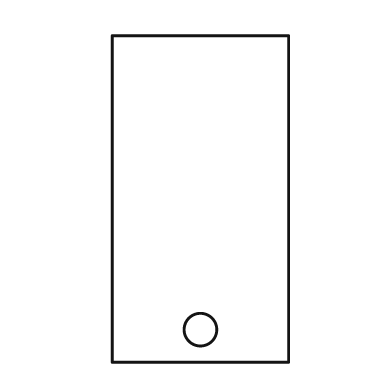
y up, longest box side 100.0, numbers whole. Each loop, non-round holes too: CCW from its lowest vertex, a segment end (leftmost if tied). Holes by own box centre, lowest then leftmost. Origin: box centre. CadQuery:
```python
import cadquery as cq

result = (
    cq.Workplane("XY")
    .moveTo(-27.0, -50.0)
    .lineTo(27.0, -50.0)
    .lineTo(27.0, 50.0)
    .lineTo(-27.0, 50.0)
    .close()
    .moveTo(0.0, -40.0)
    .circle(5.0)
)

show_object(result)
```